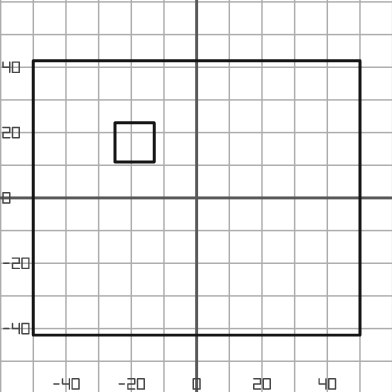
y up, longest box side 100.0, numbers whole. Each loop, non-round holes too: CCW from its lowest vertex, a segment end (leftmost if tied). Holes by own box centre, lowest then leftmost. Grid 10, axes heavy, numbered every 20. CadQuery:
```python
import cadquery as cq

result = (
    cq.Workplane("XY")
    .moveTo(-50.0, -42.0)
    .lineTo(50.0, -42.0)
    .lineTo(50.0, 42.0)
    .lineTo(-50.0, 42.0)
    .close()
    .moveTo(-25.0, 11.0)
    .lineTo(-13.0, 11.0)
    .lineTo(-13.0, 23.0)
    .lineTo(-25.0, 23.0)
    .close()
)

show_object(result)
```